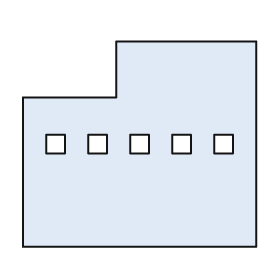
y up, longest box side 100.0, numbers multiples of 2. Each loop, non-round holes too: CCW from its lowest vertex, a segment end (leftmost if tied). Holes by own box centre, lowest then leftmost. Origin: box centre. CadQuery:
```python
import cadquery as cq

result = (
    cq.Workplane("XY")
    .moveTo(-50.0, -44.0)
    .lineTo(50.0, -44.0)
    .lineTo(50.0, 44.0)
    .lineTo(-10.0, 44.0)
    .lineTo(-10.0, 20.0)
    .lineTo(-50.0, 20.0)
    .close()
    .moveTo(-40.0, -4.0)
    .lineTo(-32.0, -4.0)
    .lineTo(-32.0, 4.0)
    .lineTo(-40.0, 4.0)
    .close()
    .moveTo(-22.0, -4.0)
    .lineTo(-14.0, -4.0)
    .lineTo(-14.0, 4.0)
    .lineTo(-22.0, 4.0)
    .close()
    .moveTo(-4.0, -4.0)
    .lineTo(4.0, -4.0)
    .lineTo(4.0, 4.0)
    .lineTo(-4.0, 4.0)
    .close()
    .moveTo(14.0, -4.0)
    .lineTo(22.0, -4.0)
    .lineTo(22.0, 4.0)
    .lineTo(14.0, 4.0)
    .close()
    .moveTo(32.0, -4.0)
    .lineTo(40.0, -4.0)
    .lineTo(40.0, 4.0)
    .lineTo(32.0, 4.0)
    .close()
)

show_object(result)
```